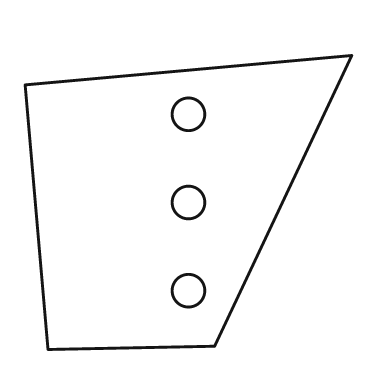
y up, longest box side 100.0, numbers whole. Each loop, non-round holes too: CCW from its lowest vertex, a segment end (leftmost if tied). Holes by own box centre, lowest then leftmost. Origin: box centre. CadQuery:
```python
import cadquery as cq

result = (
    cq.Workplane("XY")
    .moveTo(-43.0, -45.0)
    .lineTo(8.0, -44.0)
    .lineTo(50.0, 45.0)
    .lineTo(-50.0, 36.0)
    .close()
    .moveTo(0.0, -27.0)
    .circle(5.0)
    .moveTo(0.0, 0.0)
    .circle(5.0)
    .moveTo(0.0, 27.0)
    .circle(5.0)
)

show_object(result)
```